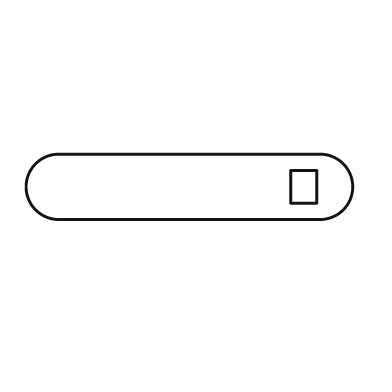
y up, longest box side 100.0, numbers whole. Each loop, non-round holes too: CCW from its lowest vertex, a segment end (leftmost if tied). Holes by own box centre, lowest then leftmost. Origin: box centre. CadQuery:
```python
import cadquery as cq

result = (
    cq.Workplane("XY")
    .moveTo(-40.0, -10.0)
    .lineTo(40.0, -10.0)
    .threePointArc((50.0, 0.0), (40.0, 10.0))
    .lineTo(-40.0, 10.0)
    .threePointArc((-50.0, 0.0), (-40.0, -10.0))
    .close()
    .moveTo(31.0, -5.0)
    .lineTo(39.0, -5.0)
    .lineTo(39.0, 5.0)
    .lineTo(31.0, 5.0)
    .close()
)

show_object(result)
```